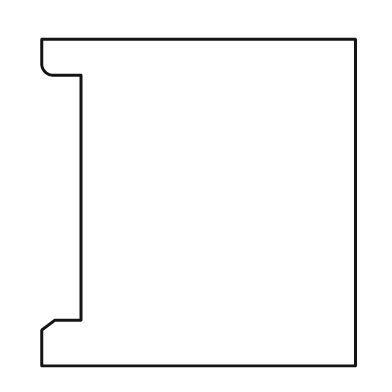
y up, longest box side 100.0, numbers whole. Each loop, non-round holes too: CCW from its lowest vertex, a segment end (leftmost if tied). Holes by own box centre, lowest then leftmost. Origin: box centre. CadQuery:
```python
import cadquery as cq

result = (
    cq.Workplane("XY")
    .moveTo(-48.0, -50.0)
    .lineTo(48.0, -50.0)
    .lineTo(48.0, 50.0)
    .lineTo(-48.0, 50.0)
    .lineTo(-48.0, 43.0)
    .threePointArc((-47.0, 40.0), (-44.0, 39.0))
    .lineTo(-36.0, 39.0)
    .lineTo(-36.0, -36.0)
    .lineTo(-44.0, -36.0)
    .lineTo(-48.0, -39.0)
    .close()
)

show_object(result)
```